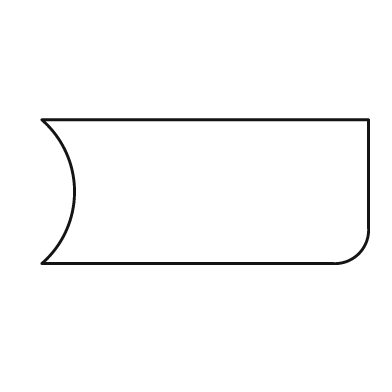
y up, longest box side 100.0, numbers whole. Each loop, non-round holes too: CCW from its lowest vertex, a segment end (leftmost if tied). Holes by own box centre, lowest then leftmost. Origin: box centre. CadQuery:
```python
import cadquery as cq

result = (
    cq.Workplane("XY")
    .moveTo(-50.0, -22.0)
    .lineTo(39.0, -22.0)
    .threePointArc((47.0, -19.0), (50.0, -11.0))
    .lineTo(50.0, 22.0)
    .lineTo(-50.0, 22.0)
    .threePointArc((-40.0, 0.0), (-50.0, -22.0))
    .close()
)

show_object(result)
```